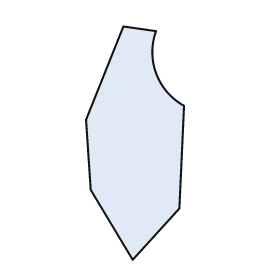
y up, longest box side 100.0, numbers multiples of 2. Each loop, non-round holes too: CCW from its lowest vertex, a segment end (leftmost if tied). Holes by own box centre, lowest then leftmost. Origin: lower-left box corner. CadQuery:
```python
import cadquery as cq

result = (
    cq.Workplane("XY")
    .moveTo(20.0, 0.0)
    .lineTo(40.0, 22.0)
    .lineTo(42.0, 66.0)
    .threePointArc((30.0, 80.0), (30.0, 98.0))
    .lineTo(16.0, 100.0)
    .lineTo(0.0, 60.0)
    .lineTo(2.0, 30.0)
    .close()
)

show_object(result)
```